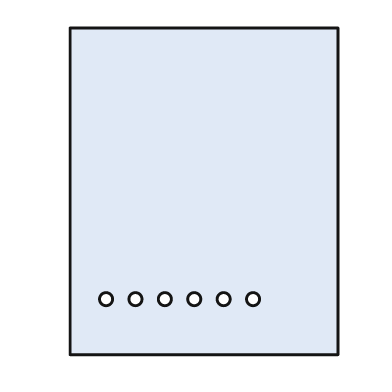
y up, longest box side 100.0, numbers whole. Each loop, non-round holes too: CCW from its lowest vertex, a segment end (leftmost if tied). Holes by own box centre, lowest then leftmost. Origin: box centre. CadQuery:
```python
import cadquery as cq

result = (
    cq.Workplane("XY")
    .moveTo(-41.0, -50.0)
    .lineTo(41.0, -50.0)
    .lineTo(41.0, 50.0)
    .lineTo(-41.0, 50.0)
    .close()
    .moveTo(-30.0, -33.0)
    .circle(2.0)
    .moveTo(-21.0, -33.0)
    .circle(2.0)
    .moveTo(-12.0, -33.0)
    .circle(2.0)
    .moveTo(-3.0, -33.0)
    .circle(2.0)
    .moveTo(6.0, -33.0)
    .circle(2.0)
    .moveTo(15.0, -33.0)
    .circle(2.0)
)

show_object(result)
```